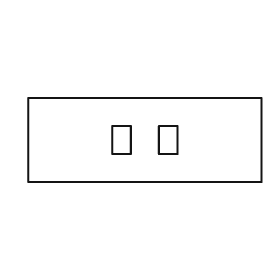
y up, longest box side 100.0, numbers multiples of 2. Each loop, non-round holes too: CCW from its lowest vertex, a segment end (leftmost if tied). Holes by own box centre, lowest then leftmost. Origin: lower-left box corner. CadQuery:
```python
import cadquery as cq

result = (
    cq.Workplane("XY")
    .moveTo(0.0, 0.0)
    .lineTo(100.0, 0.0)
    .lineTo(100.0, 36.0)
    .lineTo(0.0, 36.0)
    .close()
    .moveTo(36.0, 12.0)
    .lineTo(44.0, 12.0)
    .lineTo(44.0, 24.0)
    .lineTo(36.0, 24.0)
    .close()
    .moveTo(56.0, 12.0)
    .lineTo(64.0, 12.0)
    .lineTo(64.0, 24.0)
    .lineTo(56.0, 24.0)
    .close()
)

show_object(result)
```